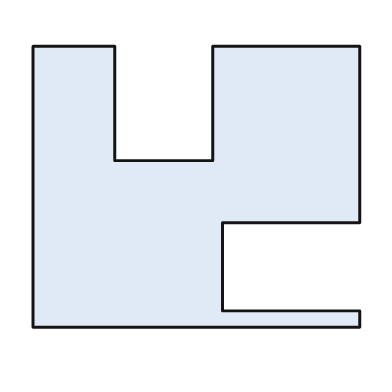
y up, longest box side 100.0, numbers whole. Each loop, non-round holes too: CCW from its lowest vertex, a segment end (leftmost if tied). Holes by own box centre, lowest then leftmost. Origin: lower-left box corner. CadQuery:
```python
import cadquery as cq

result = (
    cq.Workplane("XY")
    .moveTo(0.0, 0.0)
    .lineTo(100.0, 0.0)
    .lineTo(100.0, 5.0)
    .lineTo(58.0, 5.0)
    .lineTo(58.0, 32.0)
    .lineTo(100.0, 32.0)
    .lineTo(100.0, 86.0)
    .lineTo(55.0, 86.0)
    .lineTo(55.0, 51.0)
    .lineTo(25.0, 51.0)
    .lineTo(25.0, 86.0)
    .lineTo(0.0, 86.0)
    .close()
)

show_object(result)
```